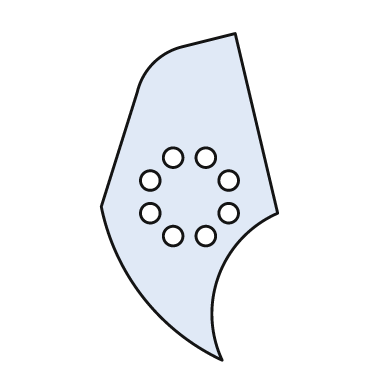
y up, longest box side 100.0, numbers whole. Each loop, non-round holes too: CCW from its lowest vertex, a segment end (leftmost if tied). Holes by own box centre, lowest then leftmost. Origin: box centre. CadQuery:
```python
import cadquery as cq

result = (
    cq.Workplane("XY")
    .moveTo(10.0, -50.0)
    .threePointArc((9.0, -24.0), (27.0, -5.0))
    .lineTo(14.0, 50.0)
    .lineTo(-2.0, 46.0)
    .threePointArc((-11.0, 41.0), (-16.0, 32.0))
    .lineTo(-27.0, -3.0)
    .threePointArc((-14.0, -31.0), (10.0, -50.0))
    .close()
    .moveTo(-5.0, -12.0)
    .circle(3.0)
    .moveTo(5.0, -12.0)
    .circle(3.0)
    .moveTo(-12.0, -5.0)
    .circle(3.0)
    .moveTo(12.0, -5.0)
    .circle(3.0)
    .moveTo(-12.0, 5.0)
    .circle(3.0)
    .moveTo(12.0, 5.0)
    .circle(3.0)
    .moveTo(-5.0, 12.0)
    .circle(3.0)
    .moveTo(5.0, 12.0)
    .circle(3.0)
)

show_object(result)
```